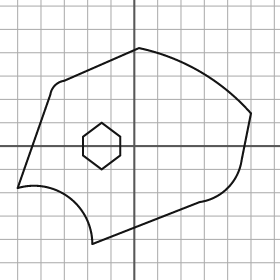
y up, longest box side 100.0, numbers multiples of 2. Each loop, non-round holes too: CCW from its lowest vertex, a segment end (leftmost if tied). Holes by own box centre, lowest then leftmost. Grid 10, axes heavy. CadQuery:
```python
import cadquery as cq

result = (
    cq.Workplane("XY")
    .moveTo(-18.0, -42.0)
    .lineTo(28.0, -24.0)
    .threePointArc((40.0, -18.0), (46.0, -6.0))
    .lineTo(50.0, 14.0)
    .threePointArc((28.0, 32.0), (2.0, 42.0))
    .lineTo(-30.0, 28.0)
    .threePointArc((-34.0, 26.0), (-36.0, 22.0))
    .lineTo(-50.0, -18.0)
    .threePointArc((-28.0, -22.0), (-18.0, -42.0))
    .close()
    .moveTo(-14.0, -10.0)
    .lineTo(-6.0, -4.0)
    .lineTo(-6.0, 4.0)
    .lineTo(-14.0, 10.0)
    .lineTo(-22.0, 4.0)
    .lineTo(-22.0, -4.0)
    .close()
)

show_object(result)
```